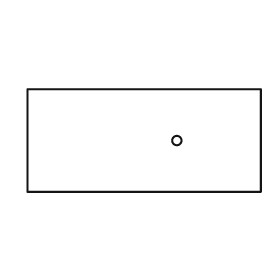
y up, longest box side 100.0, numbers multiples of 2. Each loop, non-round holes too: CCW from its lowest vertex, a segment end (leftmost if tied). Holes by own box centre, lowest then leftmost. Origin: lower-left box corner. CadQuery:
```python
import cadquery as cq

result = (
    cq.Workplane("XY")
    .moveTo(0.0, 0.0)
    .lineTo(100.0, 0.0)
    .lineTo(100.0, 44.0)
    .lineTo(0.0, 44.0)
    .close()
    .moveTo(64.0, 22.0)
    .circle(2.0)
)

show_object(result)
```